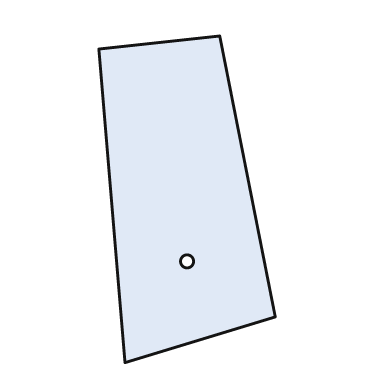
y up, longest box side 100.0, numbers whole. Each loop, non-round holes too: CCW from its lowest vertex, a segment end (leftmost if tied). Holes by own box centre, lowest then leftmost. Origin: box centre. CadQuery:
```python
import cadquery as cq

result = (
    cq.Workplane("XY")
    .moveTo(-19.0, -50.0)
    .lineTo(27.0, -36.0)
    .lineTo(10.0, 50.0)
    .lineTo(-27.0, 46.0)
    .close()
    .moveTo(0.0, -19.0)
    .circle(2.0)
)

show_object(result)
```